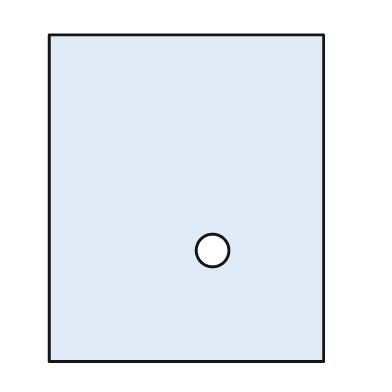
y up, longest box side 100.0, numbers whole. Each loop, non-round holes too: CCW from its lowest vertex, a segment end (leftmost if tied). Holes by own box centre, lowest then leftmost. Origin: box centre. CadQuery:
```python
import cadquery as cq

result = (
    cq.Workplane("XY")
    .moveTo(-42.0, -50.0)
    .lineTo(42.0, -50.0)
    .lineTo(42.0, 50.0)
    .lineTo(-42.0, 50.0)
    .close()
    .moveTo(8.0, -16.0)
    .circle(5.0)
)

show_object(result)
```